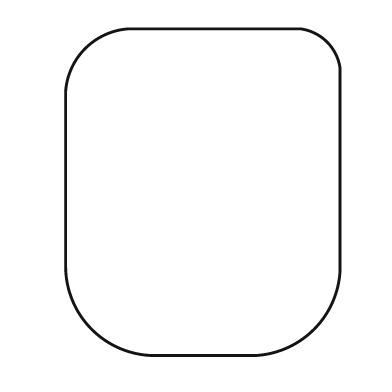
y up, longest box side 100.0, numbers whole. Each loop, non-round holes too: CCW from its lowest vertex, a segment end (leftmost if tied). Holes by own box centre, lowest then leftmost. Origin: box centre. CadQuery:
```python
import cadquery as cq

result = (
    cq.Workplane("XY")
    .moveTo(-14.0, -50.0)
    .lineTo(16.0, -50.0)
    .threePointArc((34.0, -42.0), (42.0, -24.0))
    .lineTo(42.0, 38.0)
    .threePointArc((38.0, 46.0), (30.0, 50.0))
    .lineTo(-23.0, 50.0)
    .threePointArc((-36.0, 44.0), (-42.0, 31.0))
    .lineTo(-42.0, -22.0)
    .threePointArc((-34.0, -42.0), (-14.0, -50.0))
    .close()
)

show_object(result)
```